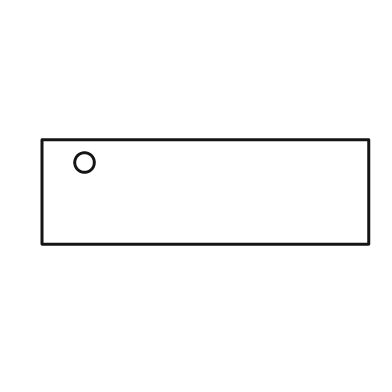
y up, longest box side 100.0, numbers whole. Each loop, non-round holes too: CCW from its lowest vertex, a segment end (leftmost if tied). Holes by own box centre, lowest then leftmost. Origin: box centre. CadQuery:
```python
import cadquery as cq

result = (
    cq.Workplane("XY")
    .moveTo(-50.0, -16.0)
    .lineTo(50.0, -16.0)
    .lineTo(50.0, 16.0)
    .lineTo(-50.0, 16.0)
    .close()
    .moveTo(-37.0, 9.0)
    .circle(3.0)
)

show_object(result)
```